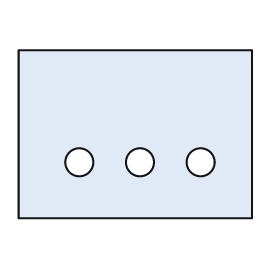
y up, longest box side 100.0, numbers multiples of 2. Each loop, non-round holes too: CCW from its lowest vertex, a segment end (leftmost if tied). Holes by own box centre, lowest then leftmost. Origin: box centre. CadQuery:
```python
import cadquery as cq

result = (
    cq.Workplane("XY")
    .moveTo(-50.0, -36.0)
    .lineTo(50.0, -36.0)
    .lineTo(50.0, 36.0)
    .lineTo(-50.0, 36.0)
    .close()
    .moveTo(-24.0, -12.0)
    .circle(6.0)
    .moveTo(2.0, -12.0)
    .circle(6.0)
    .moveTo(28.0, -12.0)
    .circle(6.0)
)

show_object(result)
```